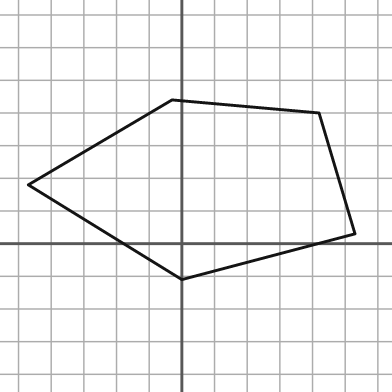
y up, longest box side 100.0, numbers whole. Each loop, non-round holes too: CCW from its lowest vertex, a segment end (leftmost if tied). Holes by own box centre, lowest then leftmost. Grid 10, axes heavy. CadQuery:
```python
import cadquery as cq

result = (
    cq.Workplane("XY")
    .moveTo(0.0, -11.0)
    .lineTo(53.0, 3.0)
    .lineTo(42.0, 40.0)
    .lineTo(-3.0, 44.0)
    .lineTo(-47.0, 18.0)
    .close()
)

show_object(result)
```